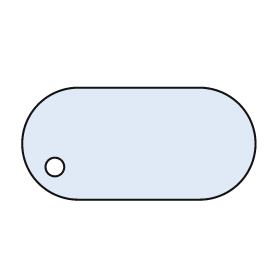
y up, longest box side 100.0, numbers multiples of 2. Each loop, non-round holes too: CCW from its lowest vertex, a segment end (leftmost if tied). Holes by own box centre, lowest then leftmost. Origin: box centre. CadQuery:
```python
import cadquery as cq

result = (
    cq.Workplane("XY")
    .moveTo(-26.0, -24.0)
    .lineTo(26.0, -24.0)
    .threePointArc((50.0, 0.0), (26.0, 24.0))
    .lineTo(-26.0, 24.0)
    .threePointArc((-50.0, 0.0), (-26.0, -24.0))
    .close()
    .moveTo(-36.0, -10.0)
    .circle(4.0)
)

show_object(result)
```